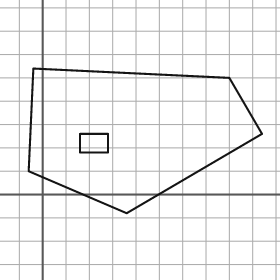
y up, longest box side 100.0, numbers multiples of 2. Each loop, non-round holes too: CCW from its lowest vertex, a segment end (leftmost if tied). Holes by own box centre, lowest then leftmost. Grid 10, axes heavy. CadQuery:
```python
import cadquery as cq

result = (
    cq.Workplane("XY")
    .moveTo(36.0, -8.0)
    .lineTo(94.0, 26.0)
    .lineTo(80.0, 50.0)
    .lineTo(-4.0, 54.0)
    .lineTo(-6.0, 10.0)
    .close()
    .moveTo(16.0, 18.0)
    .lineTo(28.0, 18.0)
    .lineTo(28.0, 26.0)
    .lineTo(16.0, 26.0)
    .close()
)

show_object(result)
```